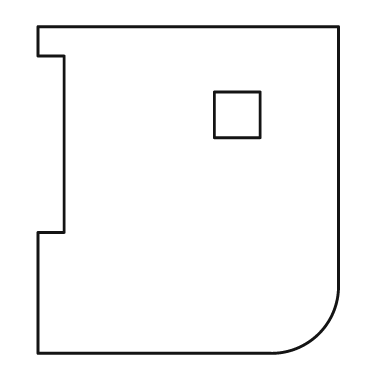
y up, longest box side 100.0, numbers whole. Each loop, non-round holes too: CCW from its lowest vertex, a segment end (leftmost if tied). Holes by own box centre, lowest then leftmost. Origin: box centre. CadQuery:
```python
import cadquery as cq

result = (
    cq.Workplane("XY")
    .moveTo(-46.0, -50.0)
    .lineTo(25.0, -50.0)
    .threePointArc((40.0, -44.0), (46.0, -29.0))
    .lineTo(46.0, 50.0)
    .lineTo(-46.0, 50.0)
    .lineTo(-46.0, 41.0)
    .lineTo(-38.0, 41.0)
    .lineTo(-38.0, -13.0)
    .lineTo(-46.0, -13.0)
    .close()
    .moveTo(8.0, 16.0)
    .lineTo(22.0, 16.0)
    .lineTo(22.0, 30.0)
    .lineTo(8.0, 30.0)
    .close()
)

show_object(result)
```